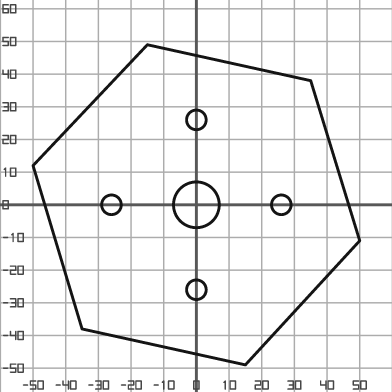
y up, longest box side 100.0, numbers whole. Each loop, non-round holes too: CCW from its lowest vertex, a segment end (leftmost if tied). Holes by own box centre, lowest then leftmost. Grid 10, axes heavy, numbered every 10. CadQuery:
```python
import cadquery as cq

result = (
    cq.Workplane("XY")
    .moveTo(15.0, -49.0)
    .lineTo(50.0, -11.0)
    .lineTo(35.0, 38.0)
    .lineTo(-15.0, 49.0)
    .lineTo(-50.0, 12.0)
    .lineTo(-35.0, -38.0)
    .close()
    .moveTo(0.0, -26.0)
    .circle(3.0)
    .moveTo(-26.0, 0.0)
    .circle(3.0)
    .moveTo(0.0, 0.0)
    .circle(7.0)
    .moveTo(26.0, 0.0)
    .circle(3.0)
    .moveTo(0.0, 26.0)
    .circle(3.0)
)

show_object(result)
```